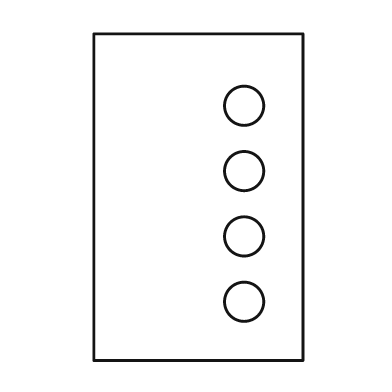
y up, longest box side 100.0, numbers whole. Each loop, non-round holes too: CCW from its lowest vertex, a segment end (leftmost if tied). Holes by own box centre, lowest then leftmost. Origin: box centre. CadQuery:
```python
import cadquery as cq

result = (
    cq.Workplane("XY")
    .moveTo(-32.0, -50.0)
    .lineTo(32.0, -50.0)
    .lineTo(32.0, 50.0)
    .lineTo(-32.0, 50.0)
    .close()
    .moveTo(14.0, -32.0)
    .circle(6.0)
    .moveTo(14.0, -12.0)
    .circle(6.0)
    .moveTo(14.0, 8.0)
    .circle(6.0)
    .moveTo(14.0, 28.0)
    .circle(6.0)
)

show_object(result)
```